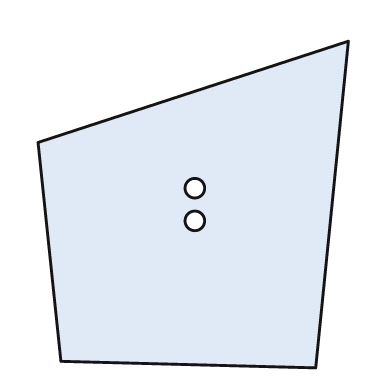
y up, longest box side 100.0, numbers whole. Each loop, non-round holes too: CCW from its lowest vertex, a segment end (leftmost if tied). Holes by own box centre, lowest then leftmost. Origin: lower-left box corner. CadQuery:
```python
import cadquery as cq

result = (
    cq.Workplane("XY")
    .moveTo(85.0, 0.0)
    .lineTo(95.0, 100.0)
    .lineTo(0.0, 69.0)
    .lineTo(7.0, 2.0)
    .close()
    .moveTo(48.0, 45.0)
    .circle(3.0)
    .moveTo(48.0, 55.0)
    .circle(3.0)
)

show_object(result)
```